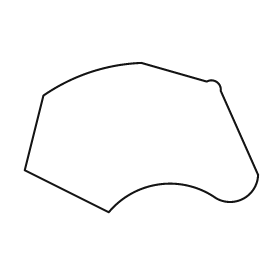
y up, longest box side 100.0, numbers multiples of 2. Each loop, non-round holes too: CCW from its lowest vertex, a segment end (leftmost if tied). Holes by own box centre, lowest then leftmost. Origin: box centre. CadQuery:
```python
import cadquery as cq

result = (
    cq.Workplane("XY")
    .moveTo(-14.0, -32.0)
    .threePointArc((8.0, -20.0), (32.0, -26.0))
    .threePointArc((44.0, -26.0), (50.0, -16.0))
    .lineTo(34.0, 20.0)
    .threePointArc((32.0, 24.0), (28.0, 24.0))
    .lineTo(0.0, 32.0)
    .threePointArc((-22.0, 28.0), (-42.0, 18.0))
    .lineTo(-50.0, -14.0)
    .close()
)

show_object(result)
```